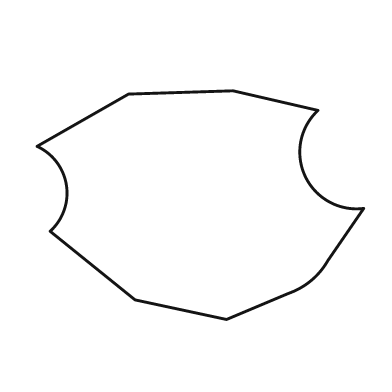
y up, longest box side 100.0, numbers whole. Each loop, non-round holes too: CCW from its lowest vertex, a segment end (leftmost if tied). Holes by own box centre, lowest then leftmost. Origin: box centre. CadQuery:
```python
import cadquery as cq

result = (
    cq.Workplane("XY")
    .moveTo(8.0, -35.0)
    .lineTo(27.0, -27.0)
    .threePointArc((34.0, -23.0), (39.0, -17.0))
    .lineTo(50.0, -1.0)
    .threePointArc((32.0, 9.0), (36.0, 29.0))
    .lineTo(10.0, 35.0)
    .lineTo(-22.0, 34.0)
    .lineTo(-50.0, 18.0)
    .threePointArc((-41.0, 6.0), (-46.0, -8.0))
    .lineTo(-20.0, -29.0)
    .close()
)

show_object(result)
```